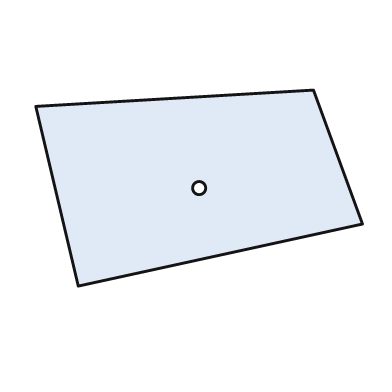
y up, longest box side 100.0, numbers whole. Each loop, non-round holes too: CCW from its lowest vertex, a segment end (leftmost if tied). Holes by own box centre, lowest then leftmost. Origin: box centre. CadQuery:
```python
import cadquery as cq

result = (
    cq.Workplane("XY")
    .moveTo(-37.0, -30.0)
    .lineTo(50.0, -11.0)
    .lineTo(35.0, 30.0)
    .lineTo(-50.0, 25.0)
    .close()
    .moveTo(0.0, 0.0)
    .circle(2.0)
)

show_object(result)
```